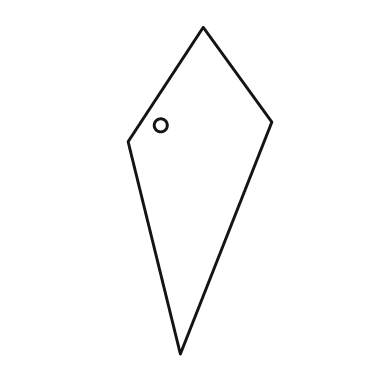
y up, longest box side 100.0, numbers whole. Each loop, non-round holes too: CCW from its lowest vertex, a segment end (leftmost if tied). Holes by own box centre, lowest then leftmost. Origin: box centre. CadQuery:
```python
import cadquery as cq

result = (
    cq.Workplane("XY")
    .moveTo(-6.0, -50.0)
    .lineTo(22.0, 21.0)
    .lineTo(1.0, 50.0)
    .lineTo(-22.0, 15.0)
    .close()
    .moveTo(-12.0, 20.0)
    .circle(2.0)
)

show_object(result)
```